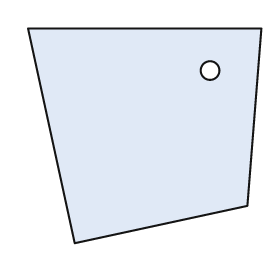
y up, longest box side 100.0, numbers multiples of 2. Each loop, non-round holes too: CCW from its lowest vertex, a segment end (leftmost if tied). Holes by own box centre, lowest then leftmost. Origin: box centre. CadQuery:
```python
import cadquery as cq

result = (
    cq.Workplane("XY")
    .moveTo(-30.0, -46.0)
    .lineTo(44.0, -30.0)
    .lineTo(50.0, 46.0)
    .lineTo(-50.0, 46.0)
    .close()
    .moveTo(28.0, 28.0)
    .circle(4.0)
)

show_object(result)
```